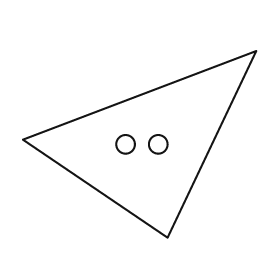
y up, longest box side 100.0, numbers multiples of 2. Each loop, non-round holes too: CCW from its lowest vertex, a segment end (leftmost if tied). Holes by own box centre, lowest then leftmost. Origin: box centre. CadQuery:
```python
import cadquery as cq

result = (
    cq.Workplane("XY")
    .moveTo(12.0, -40.0)
    .lineTo(50.0, 40.0)
    .lineTo(-50.0, 2.0)
    .close()
    .moveTo(-6.0, 0.0)
    .circle(4.0)
    .moveTo(8.0, 0.0)
    .circle(4.0)
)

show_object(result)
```